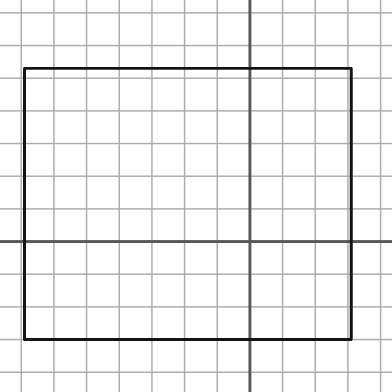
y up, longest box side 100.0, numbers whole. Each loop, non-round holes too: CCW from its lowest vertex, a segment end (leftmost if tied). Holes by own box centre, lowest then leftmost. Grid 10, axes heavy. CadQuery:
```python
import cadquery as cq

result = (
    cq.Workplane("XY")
    .moveTo(-69.0, -30.0)
    .lineTo(31.0, -30.0)
    .lineTo(31.0, 53.0)
    .lineTo(-69.0, 53.0)
    .close()
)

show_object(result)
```